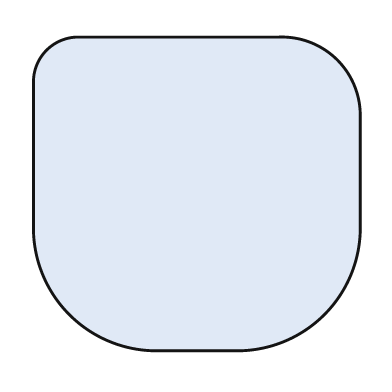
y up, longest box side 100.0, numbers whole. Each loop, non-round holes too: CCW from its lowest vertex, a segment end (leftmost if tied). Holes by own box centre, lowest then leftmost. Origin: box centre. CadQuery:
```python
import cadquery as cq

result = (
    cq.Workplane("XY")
    .moveTo(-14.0, -48.0)
    .lineTo(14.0, -48.0)
    .threePointArc((39.0, -37.0), (50.0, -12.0))
    .lineTo(50.0, 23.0)
    .threePointArc((43.0, 41.0), (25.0, 48.0))
    .lineTo(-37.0, 48.0)
    .threePointArc((-46.0, 44.0), (-50.0, 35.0))
    .lineTo(-50.0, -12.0)
    .threePointArc((-39.0, -37.0), (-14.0, -48.0))
    .close()
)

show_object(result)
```